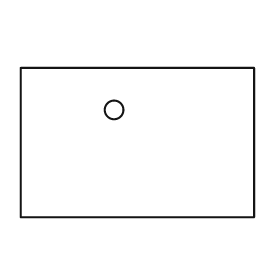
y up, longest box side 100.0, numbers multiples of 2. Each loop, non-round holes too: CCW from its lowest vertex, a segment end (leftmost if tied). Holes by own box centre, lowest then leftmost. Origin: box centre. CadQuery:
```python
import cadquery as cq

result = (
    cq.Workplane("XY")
    .moveTo(-50.0, -32.0)
    .lineTo(50.0, -32.0)
    .lineTo(50.0, 32.0)
    .lineTo(-50.0, 32.0)
    .close()
    .moveTo(-10.0, 14.0)
    .circle(4.0)
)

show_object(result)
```